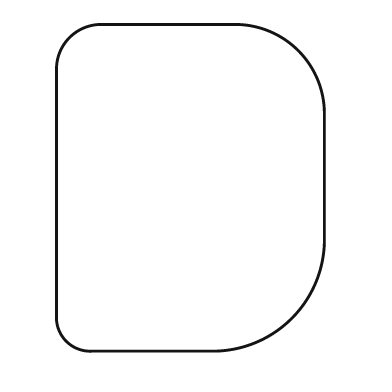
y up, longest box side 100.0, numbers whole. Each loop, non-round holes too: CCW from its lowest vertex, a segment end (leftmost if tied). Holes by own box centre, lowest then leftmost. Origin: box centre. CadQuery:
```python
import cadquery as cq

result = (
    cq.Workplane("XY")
    .moveTo(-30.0, -50.0)
    .lineTo(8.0, -50.0)
    .threePointArc((31.0, -40.0), (41.0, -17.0))
    .lineTo(41.0, 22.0)
    .threePointArc((33.0, 42.0), (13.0, 50.0))
    .lineTo(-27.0, 50.0)
    .threePointArc((-37.0, 46.0), (-41.0, 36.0))
    .lineTo(-41.0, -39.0)
    .threePointArc((-38.0, -47.0), (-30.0, -50.0))
    .close()
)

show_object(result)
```